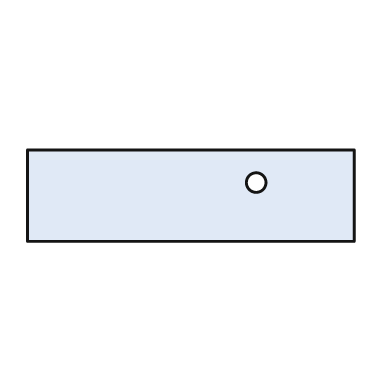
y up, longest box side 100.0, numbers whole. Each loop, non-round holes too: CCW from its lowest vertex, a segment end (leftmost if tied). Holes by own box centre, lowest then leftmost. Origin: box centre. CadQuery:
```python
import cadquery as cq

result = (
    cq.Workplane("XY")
    .moveTo(-50.0, -14.0)
    .lineTo(50.0, -14.0)
    .lineTo(50.0, 14.0)
    .lineTo(-50.0, 14.0)
    .close()
    .moveTo(20.0, 4.0)
    .circle(3.0)
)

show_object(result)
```